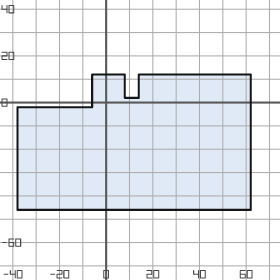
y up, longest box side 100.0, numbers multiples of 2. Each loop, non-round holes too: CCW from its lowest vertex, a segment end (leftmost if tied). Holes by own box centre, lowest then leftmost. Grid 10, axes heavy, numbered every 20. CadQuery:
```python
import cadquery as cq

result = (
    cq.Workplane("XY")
    .moveTo(-38.0, -46.0)
    .lineTo(62.0, -46.0)
    .lineTo(62.0, 12.0)
    .lineTo(14.0, 12.0)
    .lineTo(14.0, 2.0)
    .lineTo(8.0, 2.0)
    .lineTo(8.0, 12.0)
    .lineTo(-6.0, 12.0)
    .lineTo(-6.0, -2.0)
    .lineTo(-38.0, -2.0)
    .close()
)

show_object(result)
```